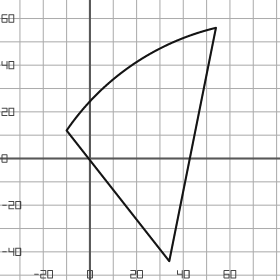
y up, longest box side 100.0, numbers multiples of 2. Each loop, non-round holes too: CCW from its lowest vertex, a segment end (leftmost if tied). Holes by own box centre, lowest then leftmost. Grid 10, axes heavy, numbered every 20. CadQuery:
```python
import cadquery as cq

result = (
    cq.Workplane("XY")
    .moveTo(34.0, -44.0)
    .lineTo(54.0, 56.0)
    .threePointArc((18.0, 40.0), (-10.0, 12.0))
    .close()
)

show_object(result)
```